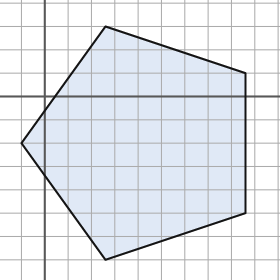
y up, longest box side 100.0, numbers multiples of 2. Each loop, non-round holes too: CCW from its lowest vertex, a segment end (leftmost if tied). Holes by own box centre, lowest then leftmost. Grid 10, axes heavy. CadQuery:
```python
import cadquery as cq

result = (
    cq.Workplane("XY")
    .moveTo(26.0, -70.0)
    .lineTo(86.0, -50.0)
    .lineTo(86.0, 10.0)
    .lineTo(26.0, 30.0)
    .lineTo(-10.0, -20.0)
    .close()
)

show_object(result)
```